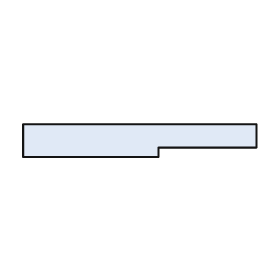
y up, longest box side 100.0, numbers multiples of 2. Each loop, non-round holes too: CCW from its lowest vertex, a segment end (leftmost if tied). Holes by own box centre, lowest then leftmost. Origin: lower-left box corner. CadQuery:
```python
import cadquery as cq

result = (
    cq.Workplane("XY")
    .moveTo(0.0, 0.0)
    .lineTo(58.0, 0.0)
    .lineTo(58.0, 4.0)
    .lineTo(100.0, 4.0)
    .lineTo(100.0, 14.0)
    .lineTo(0.0, 14.0)
    .close()
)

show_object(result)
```